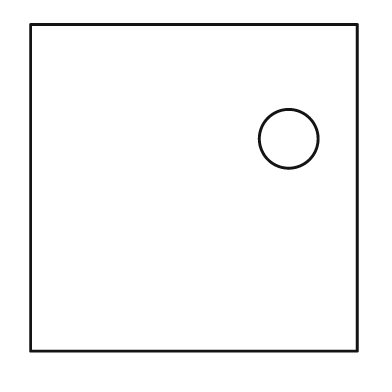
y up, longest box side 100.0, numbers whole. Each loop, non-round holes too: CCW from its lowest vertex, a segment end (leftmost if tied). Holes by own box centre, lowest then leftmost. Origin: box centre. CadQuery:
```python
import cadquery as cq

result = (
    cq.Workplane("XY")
    .moveTo(-50.0, -50.0)
    .lineTo(50.0, -50.0)
    .lineTo(50.0, 50.0)
    .lineTo(-50.0, 50.0)
    .close()
    .moveTo(29.0, 15.0)
    .circle(9.0)
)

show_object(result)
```